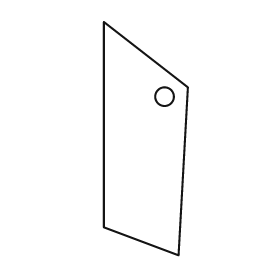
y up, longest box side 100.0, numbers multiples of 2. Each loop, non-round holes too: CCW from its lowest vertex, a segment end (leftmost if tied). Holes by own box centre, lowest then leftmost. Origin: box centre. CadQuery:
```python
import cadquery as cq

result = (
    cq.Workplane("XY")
    .moveTo(14.0, -50.0)
    .lineTo(18.0, 22.0)
    .lineTo(-18.0, 50.0)
    .lineTo(-18.0, -38.0)
    .close()
    .moveTo(8.0, 18.0)
    .circle(4.0)
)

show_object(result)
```